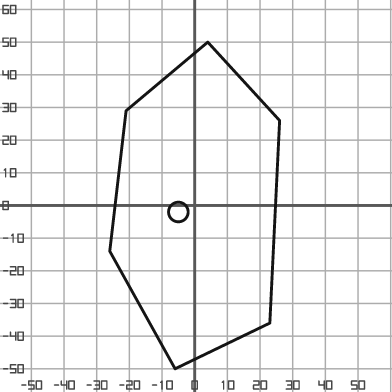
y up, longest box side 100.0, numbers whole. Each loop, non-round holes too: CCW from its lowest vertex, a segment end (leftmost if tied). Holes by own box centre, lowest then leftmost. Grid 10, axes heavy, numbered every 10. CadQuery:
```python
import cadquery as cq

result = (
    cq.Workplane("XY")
    .moveTo(-6.0, -50.0)
    .lineTo(23.0, -36.0)
    .lineTo(26.0, 26.0)
    .lineTo(4.0, 50.0)
    .lineTo(-21.0, 29.0)
    .lineTo(-26.0, -14.0)
    .close()
    .moveTo(-5.0, -2.0)
    .circle(3.0)
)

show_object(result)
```